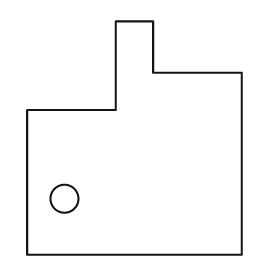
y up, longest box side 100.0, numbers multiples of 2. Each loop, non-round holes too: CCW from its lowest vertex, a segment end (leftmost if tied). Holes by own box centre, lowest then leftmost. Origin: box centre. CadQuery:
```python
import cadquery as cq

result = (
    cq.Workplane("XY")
    .moveTo(-46.0, -50.0)
    .lineTo(46.0, -50.0)
    .lineTo(46.0, 28.0)
    .lineTo(8.0, 28.0)
    .lineTo(8.0, 50.0)
    .lineTo(-8.0, 50.0)
    .lineTo(-8.0, 12.0)
    .lineTo(-46.0, 12.0)
    .close()
    .moveTo(-30.0, -26.0)
    .circle(6.0)
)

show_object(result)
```